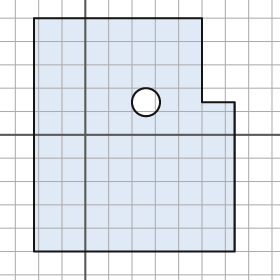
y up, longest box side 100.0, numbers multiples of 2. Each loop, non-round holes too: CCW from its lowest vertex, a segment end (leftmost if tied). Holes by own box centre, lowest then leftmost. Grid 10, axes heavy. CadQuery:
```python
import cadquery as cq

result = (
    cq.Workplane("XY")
    .moveTo(-22.0, -50.0)
    .lineTo(64.0, -50.0)
    .lineTo(64.0, 14.0)
    .lineTo(50.0, 14.0)
    .lineTo(50.0, 50.0)
    .lineTo(-22.0, 50.0)
    .close()
    .moveTo(26.0, 14.0)
    .circle(6.0)
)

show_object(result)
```